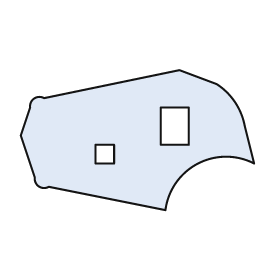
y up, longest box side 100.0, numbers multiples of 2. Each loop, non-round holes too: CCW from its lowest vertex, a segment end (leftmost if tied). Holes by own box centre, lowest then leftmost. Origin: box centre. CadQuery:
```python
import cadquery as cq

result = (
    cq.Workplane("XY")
    .moveTo(12.0, -30.0)
    .threePointArc((26.0, -10.0), (50.0, -10.0))
    .lineTo(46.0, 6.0)
    .threePointArc((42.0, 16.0), (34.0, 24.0))
    .lineTo(18.0, 30.0)
    .lineTo(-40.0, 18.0)
    .threePointArc((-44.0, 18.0), (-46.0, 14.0))
    .lineTo(-50.0, 2.0)
    .lineTo(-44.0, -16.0)
    .threePointArc((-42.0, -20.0), (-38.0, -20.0))
    .close()
    .moveTo(-18.0, -10.0)
    .lineTo(-10.0, -10.0)
    .lineTo(-10.0, -2.0)
    .lineTo(-18.0, -2.0)
    .close()
    .moveTo(10.0, -2.0)
    .lineTo(22.0, -2.0)
    .lineTo(22.0, 14.0)
    .lineTo(10.0, 14.0)
    .close()
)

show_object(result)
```